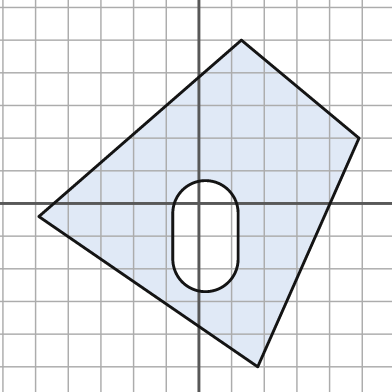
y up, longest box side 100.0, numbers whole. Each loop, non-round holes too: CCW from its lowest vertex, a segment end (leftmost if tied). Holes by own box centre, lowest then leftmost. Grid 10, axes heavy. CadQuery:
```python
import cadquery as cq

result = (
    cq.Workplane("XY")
    .moveTo(18.0, -50.0)
    .lineTo(49.0, 20.0)
    .lineTo(13.0, 50.0)
    .lineTo(-49.0, -4.0)
    .close()
    .moveTo(-8.0, -17.0)
    .threePointArc((2.0, -27.0), (12.0, -17.0))
    .lineTo(12.0, -3.0)
    .threePointArc((2.0, 7.0), (-8.0, -3.0))
    .close()
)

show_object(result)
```